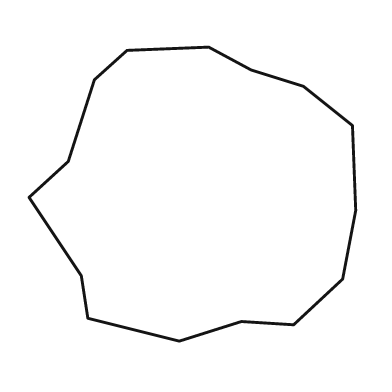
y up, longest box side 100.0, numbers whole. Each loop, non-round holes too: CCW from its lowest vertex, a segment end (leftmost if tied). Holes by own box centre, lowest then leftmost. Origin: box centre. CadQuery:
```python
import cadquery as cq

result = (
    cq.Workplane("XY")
    .moveTo(-4.0, -45.0)
    .lineTo(15.0, -39.0)
    .lineTo(31.0, -40.0)
    .lineTo(46.0, -26.0)
    .lineTo(50.0, -5.0)
    .lineTo(49.0, 21.0)
    .lineTo(34.0, 33.0)
    .lineTo(18.0, 38.0)
    .lineTo(5.0, 45.0)
    .lineTo(-20.0, 44.0)
    .lineTo(-30.0, 35.0)
    .lineTo(-38.0, 10.0)
    .lineTo(-50.0, -1.0)
    .lineTo(-34.0, -25.0)
    .lineTo(-32.0, -38.0)
    .close()
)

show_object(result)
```